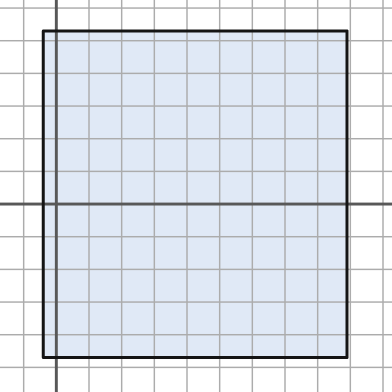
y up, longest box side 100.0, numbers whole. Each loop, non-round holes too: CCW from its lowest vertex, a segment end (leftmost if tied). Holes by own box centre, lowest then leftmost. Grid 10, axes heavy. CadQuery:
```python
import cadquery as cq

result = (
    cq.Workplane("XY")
    .moveTo(-4.0, -47.0)
    .lineTo(89.0, -47.0)
    .lineTo(89.0, 53.0)
    .lineTo(-4.0, 53.0)
    .close()
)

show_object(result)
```